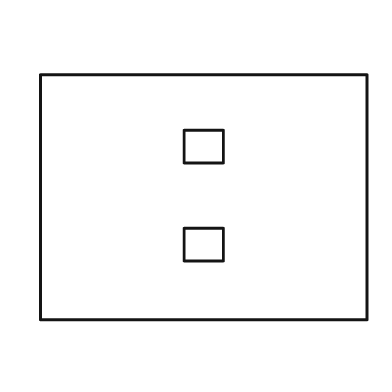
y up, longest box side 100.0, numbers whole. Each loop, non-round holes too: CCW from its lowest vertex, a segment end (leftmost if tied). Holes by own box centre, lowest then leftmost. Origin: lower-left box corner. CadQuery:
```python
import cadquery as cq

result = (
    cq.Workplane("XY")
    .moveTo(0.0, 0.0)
    .lineTo(100.0, 0.0)
    .lineTo(100.0, 75.0)
    .lineTo(0.0, 75.0)
    .close()
    .moveTo(44.0, 18.0)
    .lineTo(56.0, 18.0)
    .lineTo(56.0, 28.0)
    .lineTo(44.0, 28.0)
    .close()
    .moveTo(44.0, 48.0)
    .lineTo(56.0, 48.0)
    .lineTo(56.0, 58.0)
    .lineTo(44.0, 58.0)
    .close()
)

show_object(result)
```